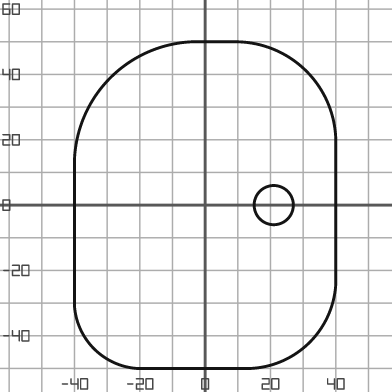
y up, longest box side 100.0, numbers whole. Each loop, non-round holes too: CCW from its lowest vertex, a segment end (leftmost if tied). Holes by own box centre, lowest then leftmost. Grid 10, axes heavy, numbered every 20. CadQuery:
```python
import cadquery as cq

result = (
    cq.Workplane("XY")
    .moveTo(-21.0, -50.0)
    .lineTo(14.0, -50.0)
    .threePointArc((32.0, -42.0), (40.0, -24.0))
    .lineTo(40.0, 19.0)
    .threePointArc((31.0, 41.0), (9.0, 50.0))
    .lineTo(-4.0, 50.0)
    .threePointArc((-29.0, 39.0), (-40.0, 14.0))
    .lineTo(-40.0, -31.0)
    .threePointArc((-34.0, -44.0), (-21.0, -50.0))
    .close()
    .moveTo(21.0, 0.0)
    .circle(6.0)
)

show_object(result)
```